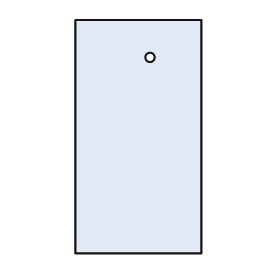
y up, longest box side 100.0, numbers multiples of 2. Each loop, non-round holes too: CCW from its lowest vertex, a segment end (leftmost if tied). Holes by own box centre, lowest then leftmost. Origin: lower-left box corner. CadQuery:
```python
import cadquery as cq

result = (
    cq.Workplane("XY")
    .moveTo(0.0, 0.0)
    .lineTo(54.0, 0.0)
    .lineTo(54.0, 100.0)
    .lineTo(0.0, 100.0)
    .close()
    .moveTo(32.0, 84.0)
    .circle(2.0)
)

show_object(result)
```